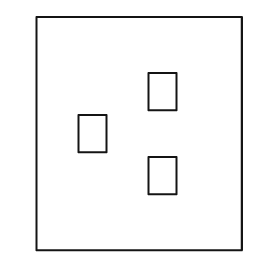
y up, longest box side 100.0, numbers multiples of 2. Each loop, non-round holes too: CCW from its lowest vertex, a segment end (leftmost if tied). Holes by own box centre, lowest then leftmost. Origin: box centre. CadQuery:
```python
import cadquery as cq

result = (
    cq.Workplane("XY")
    .moveTo(-44.0, -50.0)
    .lineTo(44.0, -50.0)
    .lineTo(44.0, 50.0)
    .lineTo(-44.0, 50.0)
    .close()
    .moveTo(4.0, -26.0)
    .lineTo(16.0, -26.0)
    .lineTo(16.0, -10.0)
    .lineTo(4.0, -10.0)
    .close()
    .moveTo(-26.0, -8.0)
    .lineTo(-14.0, -8.0)
    .lineTo(-14.0, 8.0)
    .lineTo(-26.0, 8.0)
    .close()
    .moveTo(4.0, 10.0)
    .lineTo(16.0, 10.0)
    .lineTo(16.0, 26.0)
    .lineTo(4.0, 26.0)
    .close()
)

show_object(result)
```